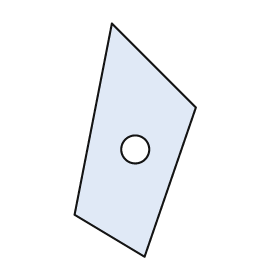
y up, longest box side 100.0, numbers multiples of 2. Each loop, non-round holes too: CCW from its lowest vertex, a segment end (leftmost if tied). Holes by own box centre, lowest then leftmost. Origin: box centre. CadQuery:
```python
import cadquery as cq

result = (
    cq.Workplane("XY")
    .moveTo(4.0, -50.0)
    .lineTo(26.0, 14.0)
    .lineTo(-10.0, 50.0)
    .lineTo(-26.0, -32.0)
    .close()
    .moveTo(0.0, -4.0)
    .circle(6.0)
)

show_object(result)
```